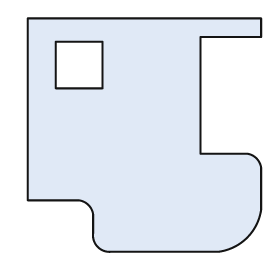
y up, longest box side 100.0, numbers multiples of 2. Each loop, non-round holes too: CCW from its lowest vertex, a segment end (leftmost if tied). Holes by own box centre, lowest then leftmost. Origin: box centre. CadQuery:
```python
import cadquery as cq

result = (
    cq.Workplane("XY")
    .moveTo(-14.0, -50.0)
    .lineTo(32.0, -50.0)
    .threePointArc((44.0, -44.0), (50.0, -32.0))
    .lineTo(50.0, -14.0)
    .threePointArc((48.0, -10.0), (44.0, -8.0))
    .lineTo(24.0, -8.0)
    .lineTo(24.0, 42.0)
    .lineTo(50.0, 42.0)
    .lineTo(50.0, 50.0)
    .lineTo(-50.0, 50.0)
    .lineTo(-50.0, -28.0)
    .lineTo(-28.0, -28.0)
    .threePointArc((-24.0, -30.0), (-22.0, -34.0))
    .lineTo(-22.0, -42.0)
    .threePointArc((-20.0, -48.0), (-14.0, -50.0))
    .close()
    .moveTo(-38.0, 20.0)
    .lineTo(-18.0, 20.0)
    .lineTo(-18.0, 40.0)
    .lineTo(-38.0, 40.0)
    .close()
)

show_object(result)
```